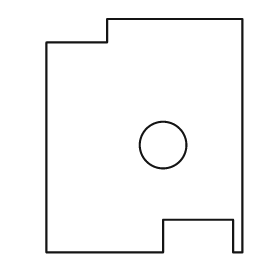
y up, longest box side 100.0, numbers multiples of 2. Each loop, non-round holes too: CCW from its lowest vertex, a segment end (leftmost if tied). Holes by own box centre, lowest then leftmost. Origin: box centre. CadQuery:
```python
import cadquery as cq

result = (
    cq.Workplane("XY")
    .moveTo(-42.0, -50.0)
    .lineTo(8.0, -50.0)
    .lineTo(8.0, -36.0)
    .lineTo(38.0, -36.0)
    .lineTo(38.0, -50.0)
    .lineTo(42.0, -50.0)
    .lineTo(42.0, 50.0)
    .lineTo(-16.0, 50.0)
    .lineTo(-16.0, 40.0)
    .lineTo(-42.0, 40.0)
    .close()
    .moveTo(8.0, -4.0)
    .circle(10.0)
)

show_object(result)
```